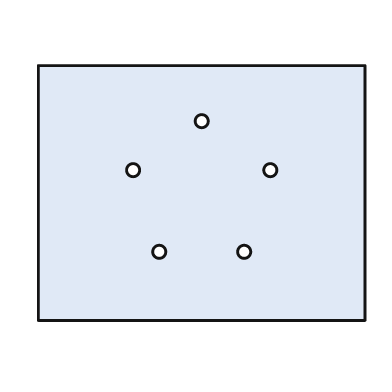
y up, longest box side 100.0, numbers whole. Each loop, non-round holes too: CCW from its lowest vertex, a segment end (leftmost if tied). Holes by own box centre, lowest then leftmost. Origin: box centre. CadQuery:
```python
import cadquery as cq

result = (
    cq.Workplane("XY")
    .moveTo(-50.0, -39.0)
    .lineTo(50.0, -39.0)
    .lineTo(50.0, 39.0)
    .lineTo(-50.0, 39.0)
    .close()
    .moveTo(-13.0, -18.0)
    .circle(2.0)
    .moveTo(13.0, -18.0)
    .circle(2.0)
    .moveTo(-21.0, 7.0)
    .circle(2.0)
    .moveTo(21.0, 7.0)
    .circle(2.0)
    .moveTo(0.0, 22.0)
    .circle(2.0)
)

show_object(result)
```